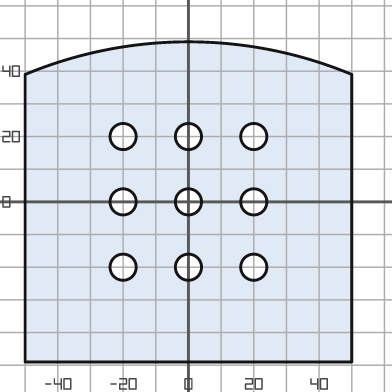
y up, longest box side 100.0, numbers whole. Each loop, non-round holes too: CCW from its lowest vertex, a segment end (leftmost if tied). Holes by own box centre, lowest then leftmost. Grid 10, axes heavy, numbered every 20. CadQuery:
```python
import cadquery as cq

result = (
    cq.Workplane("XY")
    .moveTo(-50.0, -49.0)
    .lineTo(50.0, -49.0)
    .lineTo(50.0, 39.0)
    .threePointArc((0.0, 49.0), (-50.0, 39.0))
    .close()
    .moveTo(-20.0, -20.0)
    .circle(4.0)
    .moveTo(0.0, -20.0)
    .circle(4.0)
    .moveTo(20.0, -20.0)
    .circle(4.0)
    .moveTo(-20.0, 0.0)
    .circle(4.0)
    .moveTo(0.0, 0.0)
    .circle(4.0)
    .moveTo(20.0, 0.0)
    .circle(4.0)
    .moveTo(-20.0, 20.0)
    .circle(4.0)
    .moveTo(0.0, 20.0)
    .circle(4.0)
    .moveTo(20.0, 20.0)
    .circle(4.0)
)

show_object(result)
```